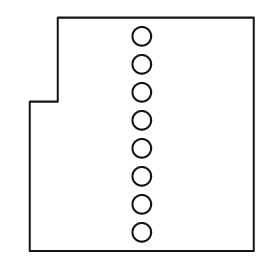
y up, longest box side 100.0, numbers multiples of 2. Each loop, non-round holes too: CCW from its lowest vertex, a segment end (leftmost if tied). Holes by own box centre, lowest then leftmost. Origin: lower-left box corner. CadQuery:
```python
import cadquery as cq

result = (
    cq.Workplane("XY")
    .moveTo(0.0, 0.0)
    .lineTo(96.0, 0.0)
    .lineTo(96.0, 100.0)
    .lineTo(12.0, 100.0)
    .lineTo(12.0, 64.0)
    .lineTo(0.0, 64.0)
    .close()
    .moveTo(48.0, 8.0)
    .circle(4.0)
    .moveTo(48.0, 20.0)
    .circle(4.0)
    .moveTo(48.0, 32.0)
    .circle(4.0)
    .moveTo(48.0, 44.0)
    .circle(4.0)
    .moveTo(48.0, 56.0)
    .circle(4.0)
    .moveTo(48.0, 68.0)
    .circle(4.0)
    .moveTo(48.0, 80.0)
    .circle(4.0)
    .moveTo(48.0, 92.0)
    .circle(4.0)
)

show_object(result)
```